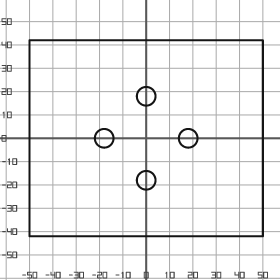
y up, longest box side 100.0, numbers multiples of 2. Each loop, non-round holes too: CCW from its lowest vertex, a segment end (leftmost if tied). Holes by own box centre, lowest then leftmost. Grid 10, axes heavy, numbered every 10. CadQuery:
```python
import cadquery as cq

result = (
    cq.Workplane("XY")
    .moveTo(-50.0, -42.0)
    .lineTo(50.0, -42.0)
    .lineTo(50.0, 42.0)
    .lineTo(-50.0, 42.0)
    .close()
    .moveTo(0.0, -18.0)
    .circle(4.0)
    .moveTo(-18.0, 0.0)
    .circle(4.0)
    .moveTo(18.0, 0.0)
    .circle(4.0)
    .moveTo(0.0, 18.0)
    .circle(4.0)
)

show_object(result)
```